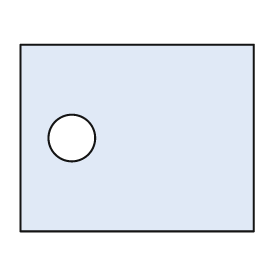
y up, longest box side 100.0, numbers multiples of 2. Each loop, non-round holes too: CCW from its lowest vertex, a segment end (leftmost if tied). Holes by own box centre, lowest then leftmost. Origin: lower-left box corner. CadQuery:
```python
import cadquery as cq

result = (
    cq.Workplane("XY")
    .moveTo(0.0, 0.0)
    .lineTo(100.0, 0.0)
    .lineTo(100.0, 80.0)
    .lineTo(0.0, 80.0)
    .close()
    .moveTo(22.0, 40.0)
    .circle(10.0)
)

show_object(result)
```